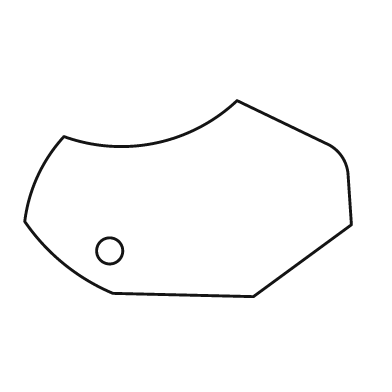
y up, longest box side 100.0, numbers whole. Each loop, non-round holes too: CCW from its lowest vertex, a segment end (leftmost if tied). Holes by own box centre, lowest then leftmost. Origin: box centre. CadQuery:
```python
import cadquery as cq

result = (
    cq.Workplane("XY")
    .moveTo(20.0, -30.0)
    .lineTo(50.0, -8.0)
    .lineTo(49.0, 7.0)
    .threePointArc((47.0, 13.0), (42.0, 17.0))
    .lineTo(15.0, 30.0)
    .threePointArc((-10.0, 17.0), (-38.0, 19.0))
    .threePointArc((-46.0, 7.0), (-50.0, -7.0))
    .threePointArc((-38.0, -20.0), (-23.0, -29.0))
    .close()
    .moveTo(-24.0, -16.0)
    .circle(4.0)
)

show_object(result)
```